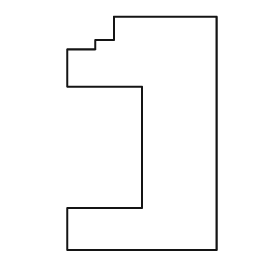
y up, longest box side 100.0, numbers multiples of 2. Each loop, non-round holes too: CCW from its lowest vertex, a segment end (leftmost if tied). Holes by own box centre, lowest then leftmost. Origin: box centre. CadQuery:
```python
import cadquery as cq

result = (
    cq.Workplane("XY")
    .moveTo(-32.0, -50.0)
    .lineTo(32.0, -50.0)
    .lineTo(32.0, 50.0)
    .lineTo(-12.0, 50.0)
    .lineTo(-12.0, 40.0)
    .lineTo(-20.0, 40.0)
    .lineTo(-20.0, 36.0)
    .lineTo(-32.0, 36.0)
    .lineTo(-32.0, 20.0)
    .lineTo(0.0, 20.0)
    .lineTo(0.0, -32.0)
    .lineTo(-32.0, -32.0)
    .close()
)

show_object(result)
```